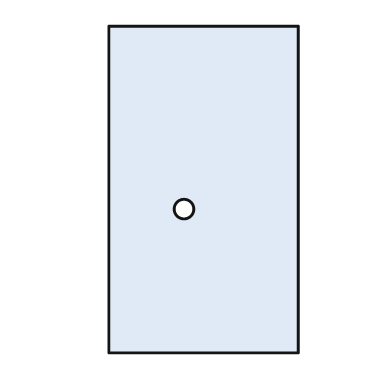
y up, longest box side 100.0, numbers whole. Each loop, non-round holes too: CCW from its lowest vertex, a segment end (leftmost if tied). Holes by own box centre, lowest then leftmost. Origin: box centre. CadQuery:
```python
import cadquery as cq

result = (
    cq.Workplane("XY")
    .moveTo(-29.0, -50.0)
    .lineTo(29.0, -50.0)
    .lineTo(29.0, 50.0)
    .lineTo(-29.0, 50.0)
    .close()
    .moveTo(-6.0, -6.0)
    .circle(3.0)
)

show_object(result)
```